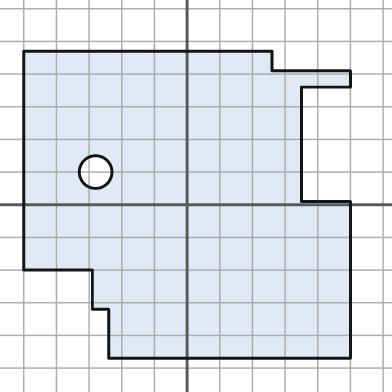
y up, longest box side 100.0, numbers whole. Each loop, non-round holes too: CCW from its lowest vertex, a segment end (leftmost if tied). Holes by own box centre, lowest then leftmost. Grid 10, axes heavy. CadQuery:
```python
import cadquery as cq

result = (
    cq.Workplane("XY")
    .moveTo(-24.0, -47.0)
    .lineTo(50.0, -47.0)
    .lineTo(50.0, 1.0)
    .lineTo(35.0, 1.0)
    .lineTo(35.0, 36.0)
    .lineTo(50.0, 36.0)
    .lineTo(50.0, 41.0)
    .lineTo(26.0, 41.0)
    .lineTo(26.0, 47.0)
    .lineTo(-50.0, 47.0)
    .lineTo(-50.0, -20.0)
    .lineTo(-29.0, -20.0)
    .lineTo(-29.0, -32.0)
    .lineTo(-24.0, -32.0)
    .close()
    .moveTo(-28.0, 10.0)
    .circle(5.0)
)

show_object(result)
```